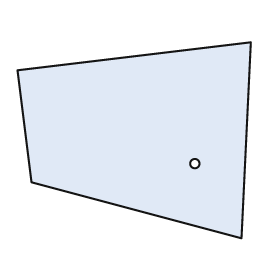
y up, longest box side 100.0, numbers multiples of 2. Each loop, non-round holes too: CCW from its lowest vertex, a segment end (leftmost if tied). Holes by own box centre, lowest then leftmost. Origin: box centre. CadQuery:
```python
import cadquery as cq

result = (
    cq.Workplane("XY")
    .moveTo(46.0, -42.0)
    .lineTo(50.0, 42.0)
    .lineTo(-50.0, 30.0)
    .lineTo(-44.0, -18.0)
    .close()
    .moveTo(26.0, -10.0)
    .circle(2.0)
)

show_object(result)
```